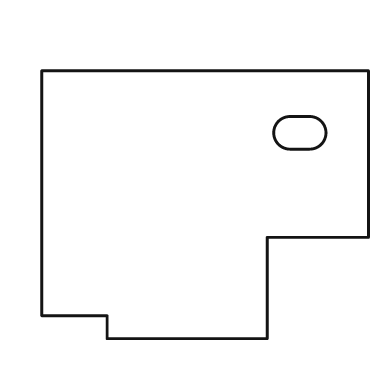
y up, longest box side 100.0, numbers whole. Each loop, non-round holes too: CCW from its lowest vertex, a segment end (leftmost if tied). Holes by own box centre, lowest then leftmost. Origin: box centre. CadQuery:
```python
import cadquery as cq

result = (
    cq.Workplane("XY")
    .moveTo(-30.0, -41.0)
    .lineTo(19.0, -41.0)
    .lineTo(19.0, -10.0)
    .lineTo(50.0, -10.0)
    .lineTo(50.0, 41.0)
    .lineTo(-50.0, 41.0)
    .lineTo(-50.0, -34.0)
    .lineTo(-30.0, -34.0)
    .close()
    .moveTo(26.0, 17.0)
    .lineTo(32.0, 17.0)
    .threePointArc((37.0, 22.0), (32.0, 27.0))
    .lineTo(26.0, 27.0)
    .threePointArc((21.0, 22.0), (26.0, 17.0))
    .close()
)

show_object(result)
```